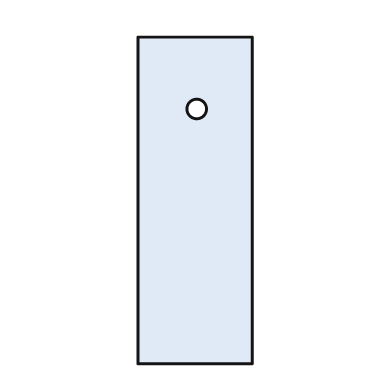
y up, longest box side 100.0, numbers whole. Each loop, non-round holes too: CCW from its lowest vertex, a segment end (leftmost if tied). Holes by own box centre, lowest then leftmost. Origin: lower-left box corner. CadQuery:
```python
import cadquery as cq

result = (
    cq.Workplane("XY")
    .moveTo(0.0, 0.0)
    .lineTo(35.0, 0.0)
    .lineTo(35.0, 100.0)
    .lineTo(0.0, 100.0)
    .close()
    .moveTo(18.0, 78.0)
    .circle(3.0)
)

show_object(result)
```